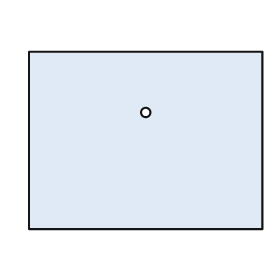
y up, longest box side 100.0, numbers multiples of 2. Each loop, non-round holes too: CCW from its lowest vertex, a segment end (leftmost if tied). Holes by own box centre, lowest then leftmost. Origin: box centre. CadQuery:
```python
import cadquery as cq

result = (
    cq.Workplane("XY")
    .moveTo(-50.0, -38.0)
    .lineTo(50.0, -38.0)
    .lineTo(50.0, 38.0)
    .lineTo(-50.0, 38.0)
    .close()
    .moveTo(0.0, 12.0)
    .circle(2.0)
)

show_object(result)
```